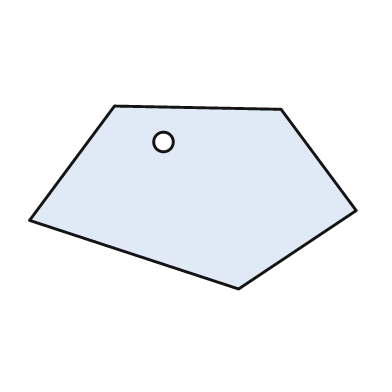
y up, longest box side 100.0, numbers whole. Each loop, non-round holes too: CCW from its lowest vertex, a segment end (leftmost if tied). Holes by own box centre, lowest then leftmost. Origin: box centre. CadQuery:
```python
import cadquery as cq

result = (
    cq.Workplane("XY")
    .moveTo(14.0, -28.0)
    .lineTo(50.0, -4.0)
    .lineTo(27.0, 27.0)
    .lineTo(-24.0, 28.0)
    .lineTo(-50.0, -7.0)
    .close()
    .moveTo(-9.0, 17.0)
    .circle(3.0)
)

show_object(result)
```